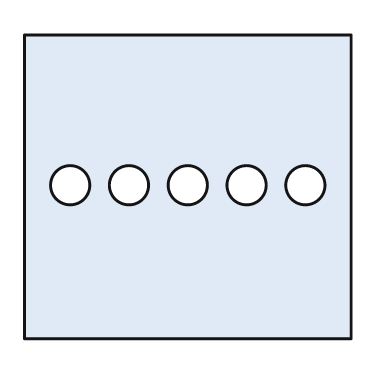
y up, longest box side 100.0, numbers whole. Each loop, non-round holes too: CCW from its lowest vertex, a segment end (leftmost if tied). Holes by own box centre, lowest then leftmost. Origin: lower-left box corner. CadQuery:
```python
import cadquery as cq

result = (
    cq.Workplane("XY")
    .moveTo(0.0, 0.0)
    .lineTo(100.0, 0.0)
    .lineTo(100.0, 93.0)
    .lineTo(0.0, 93.0)
    .close()
    .moveTo(14.0, 47.0)
    .circle(6.0)
    .moveTo(32.0, 47.0)
    .circle(6.0)
    .moveTo(50.0, 47.0)
    .circle(6.0)
    .moveTo(68.0, 47.0)
    .circle(6.0)
    .moveTo(86.0, 47.0)
    .circle(6.0)
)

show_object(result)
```